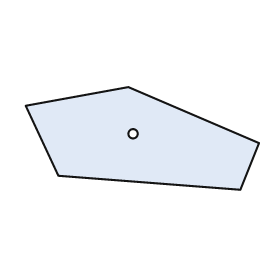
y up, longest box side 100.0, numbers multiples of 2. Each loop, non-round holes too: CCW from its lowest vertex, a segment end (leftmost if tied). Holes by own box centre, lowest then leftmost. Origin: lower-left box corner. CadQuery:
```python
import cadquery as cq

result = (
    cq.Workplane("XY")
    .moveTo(92.0, 0.0)
    .lineTo(100.0, 20.0)
    .lineTo(44.0, 44.0)
    .lineTo(0.0, 36.0)
    .lineTo(14.0, 6.0)
    .close()
    .moveTo(46.0, 24.0)
    .circle(2.0)
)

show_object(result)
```